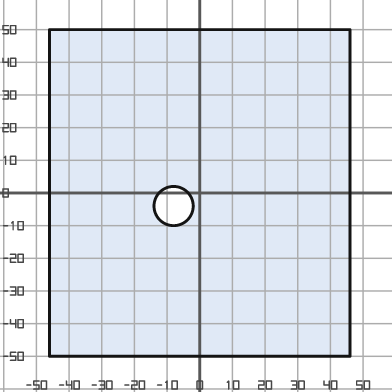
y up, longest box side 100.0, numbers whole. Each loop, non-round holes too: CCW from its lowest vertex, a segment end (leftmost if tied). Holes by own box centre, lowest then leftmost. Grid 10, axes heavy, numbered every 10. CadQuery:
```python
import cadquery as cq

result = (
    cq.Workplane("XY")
    .moveTo(-46.0, -50.0)
    .lineTo(46.0, -50.0)
    .lineTo(46.0, 50.0)
    .lineTo(-46.0, 50.0)
    .close()
    .moveTo(-8.0, -4.0)
    .circle(6.0)
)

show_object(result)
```